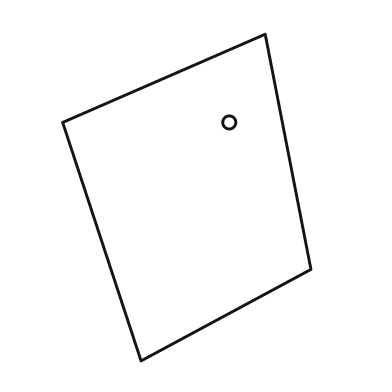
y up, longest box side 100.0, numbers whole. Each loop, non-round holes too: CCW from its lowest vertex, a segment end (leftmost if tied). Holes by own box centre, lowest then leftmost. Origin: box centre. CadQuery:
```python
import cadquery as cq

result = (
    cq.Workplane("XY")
    .moveTo(-14.0, -50.0)
    .lineTo(38.0, -22.0)
    .lineTo(24.0, 50.0)
    .lineTo(-38.0, 23.0)
    .close()
    .moveTo(13.0, 23.0)
    .circle(2.0)
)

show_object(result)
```